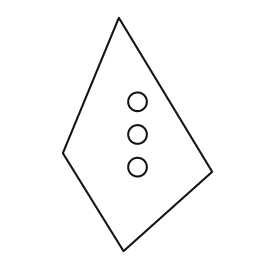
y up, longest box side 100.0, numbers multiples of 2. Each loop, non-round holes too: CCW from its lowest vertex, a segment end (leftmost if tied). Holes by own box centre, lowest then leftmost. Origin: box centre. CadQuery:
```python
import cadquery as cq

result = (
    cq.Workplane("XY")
    .moveTo(-6.0, -50.0)
    .lineTo(32.0, -16.0)
    .lineTo(-8.0, 50.0)
    .lineTo(-32.0, -8.0)
    .close()
    .moveTo(0.0, -14.0)
    .circle(4.0)
    .moveTo(0.0, 0.0)
    .circle(4.0)
    .moveTo(0.0, 14.0)
    .circle(4.0)
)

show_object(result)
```